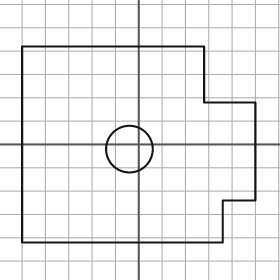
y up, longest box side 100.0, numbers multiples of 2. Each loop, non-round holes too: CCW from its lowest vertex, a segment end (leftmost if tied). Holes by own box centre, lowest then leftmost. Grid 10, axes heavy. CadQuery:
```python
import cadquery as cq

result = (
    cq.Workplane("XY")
    .moveTo(-50.0, -42.0)
    .lineTo(36.0, -42.0)
    .lineTo(36.0, -24.0)
    .lineTo(50.0, -24.0)
    .lineTo(50.0, 18.0)
    .lineTo(28.0, 18.0)
    .lineTo(28.0, 42.0)
    .lineTo(-50.0, 42.0)
    .close()
    .moveTo(-4.0, -2.0)
    .circle(10.0)
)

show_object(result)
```